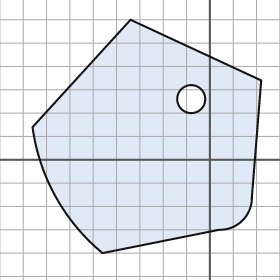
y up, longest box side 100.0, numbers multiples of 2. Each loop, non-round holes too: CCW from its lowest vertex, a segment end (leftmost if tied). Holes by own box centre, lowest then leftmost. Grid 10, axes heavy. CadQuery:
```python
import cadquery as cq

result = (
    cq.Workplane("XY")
    .moveTo(-46.0, -40.0)
    .lineTo(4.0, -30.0)
    .threePointArc((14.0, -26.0), (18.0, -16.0))
    .lineTo(22.0, 34.0)
    .lineTo(-34.0, 60.0)
    .lineTo(-76.0, 14.0)
    .threePointArc((-66.0, -16.0), (-46.0, -40.0))
    .close()
    .moveTo(-8.0, 26.0)
    .circle(6.0)
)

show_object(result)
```